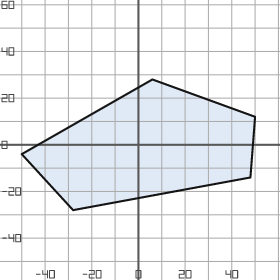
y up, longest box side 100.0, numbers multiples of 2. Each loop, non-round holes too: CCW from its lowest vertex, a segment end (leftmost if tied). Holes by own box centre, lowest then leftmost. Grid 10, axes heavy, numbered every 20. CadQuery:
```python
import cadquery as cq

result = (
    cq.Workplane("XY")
    .moveTo(-28.0, -28.0)
    .lineTo(48.0, -14.0)
    .lineTo(50.0, 12.0)
    .lineTo(6.0, 28.0)
    .lineTo(-50.0, -4.0)
    .close()
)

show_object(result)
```